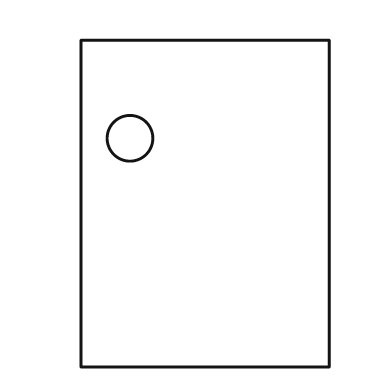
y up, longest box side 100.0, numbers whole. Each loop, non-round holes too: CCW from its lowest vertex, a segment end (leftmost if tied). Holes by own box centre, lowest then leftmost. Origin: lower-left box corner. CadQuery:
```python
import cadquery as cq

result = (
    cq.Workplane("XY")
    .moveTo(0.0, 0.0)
    .lineTo(76.0, 0.0)
    .lineTo(76.0, 100.0)
    .lineTo(0.0, 100.0)
    .close()
    .moveTo(15.0, 70.0)
    .circle(7.0)
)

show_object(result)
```